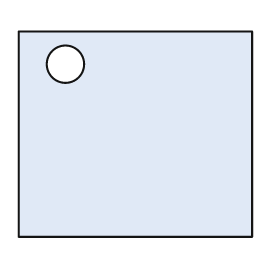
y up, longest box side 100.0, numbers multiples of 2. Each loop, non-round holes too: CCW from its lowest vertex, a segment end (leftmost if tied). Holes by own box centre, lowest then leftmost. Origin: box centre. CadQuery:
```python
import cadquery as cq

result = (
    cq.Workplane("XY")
    .moveTo(-50.0, -44.0)
    .lineTo(50.0, -44.0)
    .lineTo(50.0, 44.0)
    .lineTo(-50.0, 44.0)
    .close()
    .moveTo(-30.0, 30.0)
    .circle(8.0)
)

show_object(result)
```